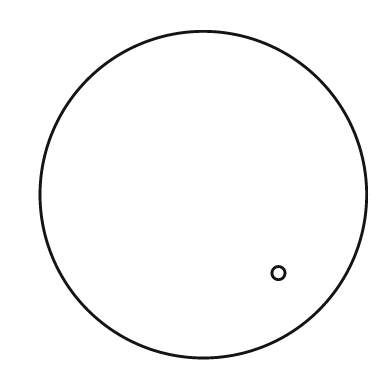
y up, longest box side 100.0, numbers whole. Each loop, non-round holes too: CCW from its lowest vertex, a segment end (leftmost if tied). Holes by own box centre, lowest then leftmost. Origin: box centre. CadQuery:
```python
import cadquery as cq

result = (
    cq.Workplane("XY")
    .moveTo(0.0, 0.0)
    .circle(50.0)
    .moveTo(23.0, -24.0)
    .circle(2.0)
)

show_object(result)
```